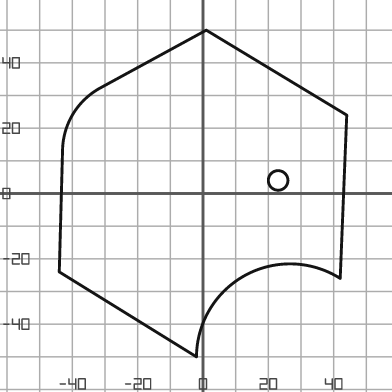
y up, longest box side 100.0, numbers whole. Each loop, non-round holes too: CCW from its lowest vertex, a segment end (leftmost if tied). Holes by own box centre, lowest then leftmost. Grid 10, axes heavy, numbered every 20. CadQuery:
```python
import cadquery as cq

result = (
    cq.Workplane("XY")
    .moveTo(-2.0, -50.0)
    .threePointArc((13.0, -25.0), (42.0, -26.0))
    .lineTo(44.0, 24.0)
    .lineTo(1.0, 50.0)
    .lineTo(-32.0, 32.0)
    .threePointArc((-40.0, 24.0), (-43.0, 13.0))
    .lineTo(-44.0, -24.0)
    .close()
    .moveTo(23.0, 4.0)
    .circle(3.0)
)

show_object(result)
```